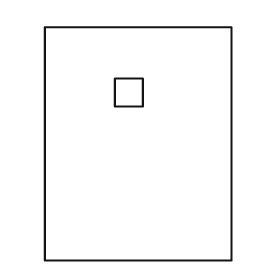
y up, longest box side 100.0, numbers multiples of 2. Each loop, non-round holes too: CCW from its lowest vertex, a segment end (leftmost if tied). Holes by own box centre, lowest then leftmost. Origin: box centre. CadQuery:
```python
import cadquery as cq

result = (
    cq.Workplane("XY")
    .moveTo(-40.0, -50.0)
    .lineTo(40.0, -50.0)
    .lineTo(40.0, 50.0)
    .lineTo(-40.0, 50.0)
    .close()
    .moveTo(-10.0, 16.0)
    .lineTo(2.0, 16.0)
    .lineTo(2.0, 28.0)
    .lineTo(-10.0, 28.0)
    .close()
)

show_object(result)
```